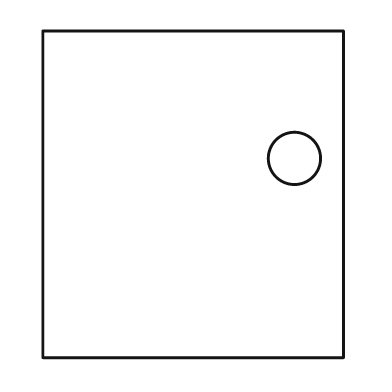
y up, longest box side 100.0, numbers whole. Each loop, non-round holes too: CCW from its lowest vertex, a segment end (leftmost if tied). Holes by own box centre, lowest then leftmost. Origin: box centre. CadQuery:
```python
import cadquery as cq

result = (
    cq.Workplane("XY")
    .moveTo(-46.0, -50.0)
    .lineTo(46.0, -50.0)
    .lineTo(46.0, 50.0)
    .lineTo(-46.0, 50.0)
    .close()
    .moveTo(31.0, 11.0)
    .circle(8.0)
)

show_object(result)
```